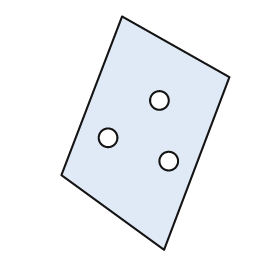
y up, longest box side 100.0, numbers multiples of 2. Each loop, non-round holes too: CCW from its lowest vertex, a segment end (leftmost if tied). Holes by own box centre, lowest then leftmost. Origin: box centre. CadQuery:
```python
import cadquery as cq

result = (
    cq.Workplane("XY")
    .moveTo(8.0, -50.0)
    .lineTo(36.0, 24.0)
    .lineTo(-10.0, 50.0)
    .lineTo(-36.0, -18.0)
    .close()
    .moveTo(10.0, -12.0)
    .circle(4.0)
    .moveTo(-16.0, -2.0)
    .circle(4.0)
    .moveTo(6.0, 14.0)
    .circle(4.0)
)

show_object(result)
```